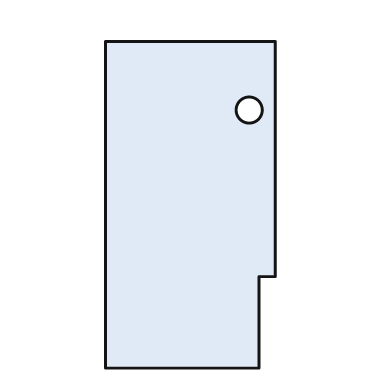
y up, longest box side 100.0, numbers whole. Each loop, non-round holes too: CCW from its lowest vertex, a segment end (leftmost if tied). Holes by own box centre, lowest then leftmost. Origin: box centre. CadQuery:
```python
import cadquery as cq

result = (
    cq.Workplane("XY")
    .moveTo(-26.0, -50.0)
    .lineTo(21.0, -50.0)
    .lineTo(21.0, -22.0)
    .lineTo(26.0, -22.0)
    .lineTo(26.0, 50.0)
    .lineTo(-26.0, 50.0)
    .close()
    .moveTo(18.0, 29.0)
    .circle(4.0)
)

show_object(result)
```